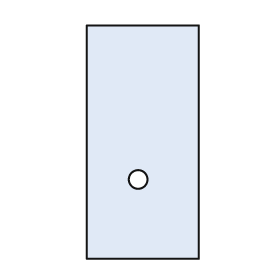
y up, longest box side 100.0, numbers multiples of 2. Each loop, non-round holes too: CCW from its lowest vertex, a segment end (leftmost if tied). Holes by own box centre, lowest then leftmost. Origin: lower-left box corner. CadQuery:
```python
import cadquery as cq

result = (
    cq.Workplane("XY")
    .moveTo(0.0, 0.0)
    .lineTo(48.0, 0.0)
    .lineTo(48.0, 100.0)
    .lineTo(0.0, 100.0)
    .close()
    .moveTo(22.0, 34.0)
    .circle(4.0)
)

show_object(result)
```